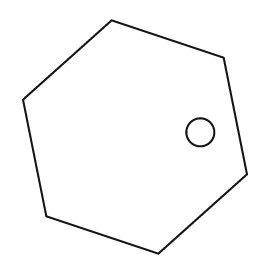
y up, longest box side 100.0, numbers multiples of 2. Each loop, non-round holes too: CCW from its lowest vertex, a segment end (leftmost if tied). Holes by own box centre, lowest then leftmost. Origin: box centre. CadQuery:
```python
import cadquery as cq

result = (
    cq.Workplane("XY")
    .moveTo(10.0, -50.0)
    .lineTo(48.0, -16.0)
    .lineTo(38.0, 34.0)
    .lineTo(-10.0, 50.0)
    .lineTo(-48.0, 16.0)
    .lineTo(-38.0, -34.0)
    .close()
    .moveTo(28.0, 2.0)
    .circle(6.0)
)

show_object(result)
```